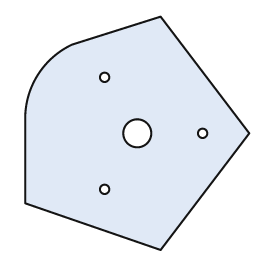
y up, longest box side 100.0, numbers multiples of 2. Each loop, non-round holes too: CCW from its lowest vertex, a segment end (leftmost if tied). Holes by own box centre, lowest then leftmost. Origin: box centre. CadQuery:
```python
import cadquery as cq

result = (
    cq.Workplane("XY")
    .moveTo(10.0, -50.0)
    .lineTo(48.0, 0.0)
    .lineTo(10.0, 50.0)
    .lineTo(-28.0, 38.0)
    .threePointArc((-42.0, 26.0), (-48.0, 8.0))
    .lineTo(-48.0, -30.0)
    .close()
    .moveTo(-14.0, -24.0)
    .circle(2.0)
    .moveTo(0.0, 0.0)
    .circle(6.0)
    .moveTo(28.0, 0.0)
    .circle(2.0)
    .moveTo(-14.0, 24.0)
    .circle(2.0)
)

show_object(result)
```